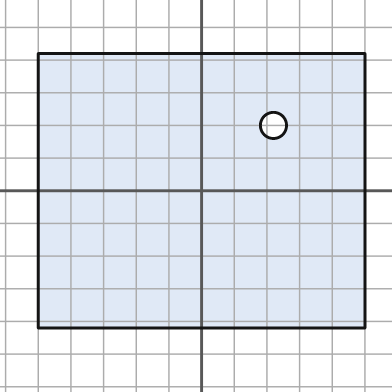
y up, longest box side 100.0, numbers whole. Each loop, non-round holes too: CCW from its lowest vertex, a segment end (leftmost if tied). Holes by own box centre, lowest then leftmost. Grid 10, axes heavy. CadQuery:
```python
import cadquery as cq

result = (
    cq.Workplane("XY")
    .moveTo(-50.0, -42.0)
    .lineTo(50.0, -42.0)
    .lineTo(50.0, 42.0)
    .lineTo(-50.0, 42.0)
    .close()
    .moveTo(22.0, 20.0)
    .circle(4.0)
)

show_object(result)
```